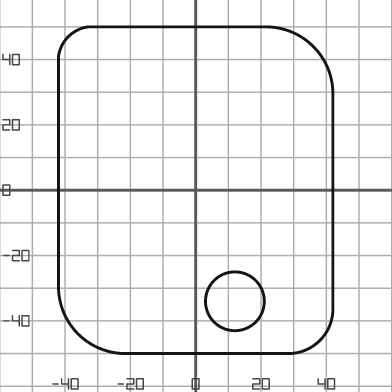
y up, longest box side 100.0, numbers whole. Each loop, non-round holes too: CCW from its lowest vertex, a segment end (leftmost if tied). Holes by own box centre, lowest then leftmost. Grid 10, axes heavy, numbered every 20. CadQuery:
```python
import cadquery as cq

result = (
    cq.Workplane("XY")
    .moveTo(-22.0, -50.0)
    .lineTo(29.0, -50.0)
    .threePointArc((38.0, -46.0), (42.0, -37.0))
    .lineTo(42.0, 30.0)
    .threePointArc((36.0, 44.0), (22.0, 50.0))
    .lineTo(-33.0, 50.0)
    .threePointArc((-39.0, 47.0), (-42.0, 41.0))
    .lineTo(-42.0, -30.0)
    .threePointArc((-36.0, -44.0), (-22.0, -50.0))
    .close()
    .moveTo(12.0, -34.0)
    .circle(9.0)
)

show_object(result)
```